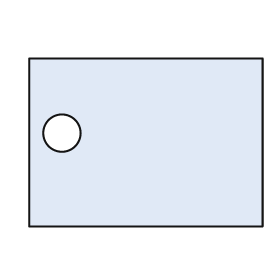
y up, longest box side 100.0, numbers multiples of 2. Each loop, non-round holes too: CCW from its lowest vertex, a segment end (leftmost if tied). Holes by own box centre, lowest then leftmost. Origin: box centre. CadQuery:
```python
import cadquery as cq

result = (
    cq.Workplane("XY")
    .moveTo(-50.0, -36.0)
    .lineTo(50.0, -36.0)
    .lineTo(50.0, 36.0)
    .lineTo(-50.0, 36.0)
    .close()
    .moveTo(-36.0, 4.0)
    .circle(8.0)
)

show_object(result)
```